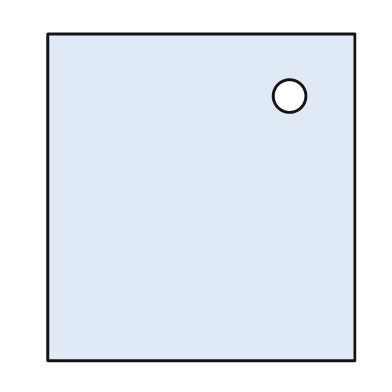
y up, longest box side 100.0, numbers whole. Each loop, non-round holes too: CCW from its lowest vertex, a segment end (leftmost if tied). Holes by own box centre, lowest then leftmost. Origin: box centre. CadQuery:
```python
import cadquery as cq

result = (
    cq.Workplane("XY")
    .moveTo(-47.0, -50.0)
    .lineTo(47.0, -50.0)
    .lineTo(47.0, 50.0)
    .lineTo(-47.0, 50.0)
    .close()
    .moveTo(27.0, 31.0)
    .circle(5.0)
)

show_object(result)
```